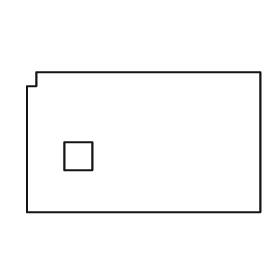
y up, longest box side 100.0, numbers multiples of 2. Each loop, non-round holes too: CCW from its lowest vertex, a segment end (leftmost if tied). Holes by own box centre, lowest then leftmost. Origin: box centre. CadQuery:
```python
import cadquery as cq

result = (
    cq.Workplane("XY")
    .moveTo(-50.0, -30.0)
    .lineTo(50.0, -30.0)
    .lineTo(50.0, 30.0)
    .lineTo(-46.0, 30.0)
    .lineTo(-46.0, 24.0)
    .lineTo(-50.0, 24.0)
    .close()
    .moveTo(-34.0, -12.0)
    .lineTo(-22.0, -12.0)
    .lineTo(-22.0, 0.0)
    .lineTo(-34.0, 0.0)
    .close()
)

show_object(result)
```